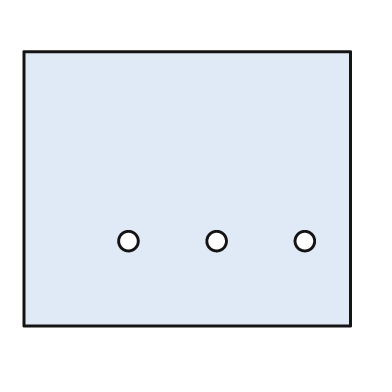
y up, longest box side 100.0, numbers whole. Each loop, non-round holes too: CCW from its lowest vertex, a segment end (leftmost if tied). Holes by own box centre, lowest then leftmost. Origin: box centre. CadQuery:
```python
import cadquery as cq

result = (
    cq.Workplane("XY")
    .moveTo(-50.0, -42.0)
    .lineTo(50.0, -42.0)
    .lineTo(50.0, 42.0)
    .lineTo(-50.0, 42.0)
    .close()
    .moveTo(-18.0, -16.0)
    .circle(3.0)
    .moveTo(9.0, -16.0)
    .circle(3.0)
    .moveTo(36.0, -16.0)
    .circle(3.0)
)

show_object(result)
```